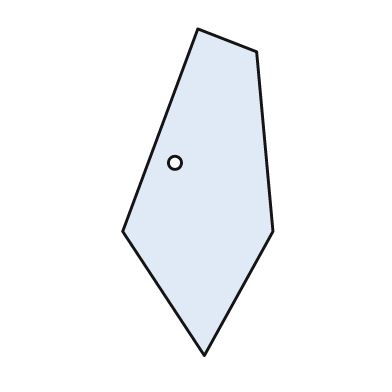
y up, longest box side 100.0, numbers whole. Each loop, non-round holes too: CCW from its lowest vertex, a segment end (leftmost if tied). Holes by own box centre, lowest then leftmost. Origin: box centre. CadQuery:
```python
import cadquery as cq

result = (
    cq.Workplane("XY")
    .moveTo(2.0, -50.0)
    .lineTo(23.0, -12.0)
    .lineTo(18.0, 43.0)
    .lineTo(0.0, 50.0)
    .lineTo(-23.0, -12.0)
    .close()
    .moveTo(-7.0, 9.0)
    .circle(2.0)
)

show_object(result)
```